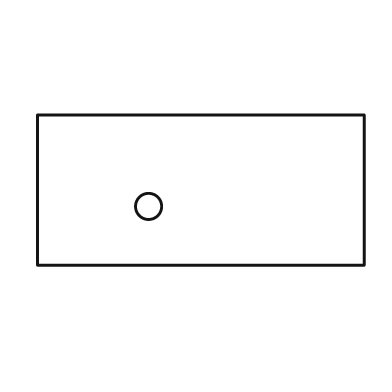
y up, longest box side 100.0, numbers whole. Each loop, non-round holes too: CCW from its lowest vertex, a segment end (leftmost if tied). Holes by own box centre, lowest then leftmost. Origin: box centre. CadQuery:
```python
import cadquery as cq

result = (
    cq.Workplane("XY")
    .moveTo(-50.0, -23.0)
    .lineTo(50.0, -23.0)
    .lineTo(50.0, 23.0)
    .lineTo(-50.0, 23.0)
    .close()
    .moveTo(-16.0, -5.0)
    .circle(4.0)
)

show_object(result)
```